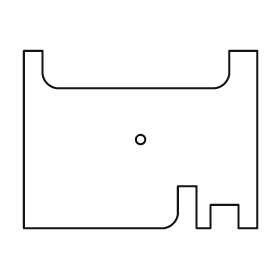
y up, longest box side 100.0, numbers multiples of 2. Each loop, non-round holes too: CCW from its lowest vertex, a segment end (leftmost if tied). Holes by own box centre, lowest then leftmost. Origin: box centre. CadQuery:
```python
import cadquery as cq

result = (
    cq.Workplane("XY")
    .moveTo(-50.0, -38.0)
    .lineTo(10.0, -38.0)
    .threePointArc((14.0, -36.0), (16.0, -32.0))
    .lineTo(16.0, -20.0)
    .lineTo(24.0, -20.0)
    .lineTo(24.0, -38.0)
    .lineTo(30.0, -38.0)
    .lineTo(30.0, -28.0)
    .lineTo(42.0, -28.0)
    .lineTo(42.0, -38.0)
    .lineTo(50.0, -38.0)
    .lineTo(50.0, 38.0)
    .lineTo(38.0, 38.0)
    .lineTo(38.0, 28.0)
    .threePointArc((36.0, 24.0), (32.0, 22.0))
    .lineTo(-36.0, 22.0)
    .threePointArc((-40.0, 24.0), (-42.0, 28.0))
    .lineTo(-42.0, 38.0)
    .lineTo(-50.0, 38.0)
    .close()
    .moveTo(0.0, 0.0)
    .circle(2.0)
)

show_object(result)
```